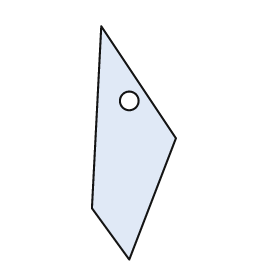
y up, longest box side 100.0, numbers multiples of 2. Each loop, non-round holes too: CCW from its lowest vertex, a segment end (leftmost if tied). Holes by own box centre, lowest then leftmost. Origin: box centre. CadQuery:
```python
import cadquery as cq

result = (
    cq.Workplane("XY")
    .moveTo(-2.0, -50.0)
    .lineTo(18.0, 2.0)
    .lineTo(-14.0, 50.0)
    .lineTo(-18.0, -28.0)
    .close()
    .moveTo(-2.0, 18.0)
    .circle(4.0)
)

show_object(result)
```